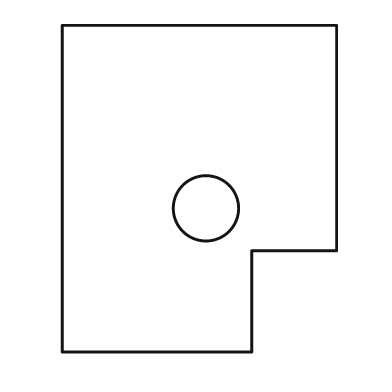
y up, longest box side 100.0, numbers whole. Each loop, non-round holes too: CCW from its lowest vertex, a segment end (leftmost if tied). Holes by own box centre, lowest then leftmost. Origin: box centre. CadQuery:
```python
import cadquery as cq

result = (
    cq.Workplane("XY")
    .moveTo(-42.0, -50.0)
    .lineTo(16.0, -50.0)
    .lineTo(16.0, -19.0)
    .lineTo(42.0, -19.0)
    .lineTo(42.0, 50.0)
    .lineTo(-42.0, 50.0)
    .close()
    .moveTo(2.0, -6.0)
    .circle(10.0)
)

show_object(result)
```